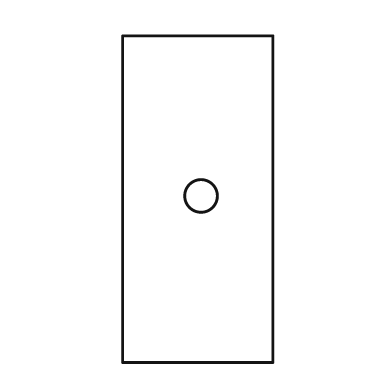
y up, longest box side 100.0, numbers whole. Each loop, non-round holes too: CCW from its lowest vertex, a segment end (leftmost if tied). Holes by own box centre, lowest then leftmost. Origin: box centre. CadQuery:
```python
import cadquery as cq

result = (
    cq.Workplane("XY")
    .moveTo(-23.0, -50.0)
    .lineTo(23.0, -50.0)
    .lineTo(23.0, 50.0)
    .lineTo(-23.0, 50.0)
    .close()
    .moveTo(1.0, 1.0)
    .circle(5.0)
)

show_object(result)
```